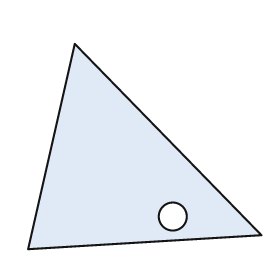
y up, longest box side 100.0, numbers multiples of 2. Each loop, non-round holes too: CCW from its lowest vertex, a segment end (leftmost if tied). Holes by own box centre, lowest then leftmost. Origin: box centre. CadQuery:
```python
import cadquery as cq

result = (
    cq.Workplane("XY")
    .moveTo(-50.0, -44.0)
    .lineTo(50.0, -38.0)
    .lineTo(-30.0, 44.0)
    .close()
    .moveTo(12.0, -30.0)
    .circle(6.0)
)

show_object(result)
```